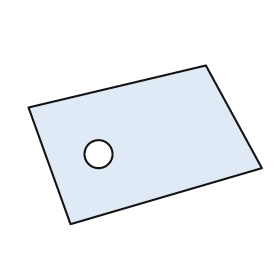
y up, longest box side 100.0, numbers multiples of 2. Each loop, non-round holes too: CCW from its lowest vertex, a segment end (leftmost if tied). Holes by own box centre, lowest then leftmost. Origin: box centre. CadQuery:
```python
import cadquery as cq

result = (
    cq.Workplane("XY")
    .moveTo(-32.0, -34.0)
    .lineTo(50.0, -10.0)
    .lineTo(26.0, 34.0)
    .lineTo(-50.0, 16.0)
    .close()
    .moveTo(-20.0, -4.0)
    .circle(6.0)
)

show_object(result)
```